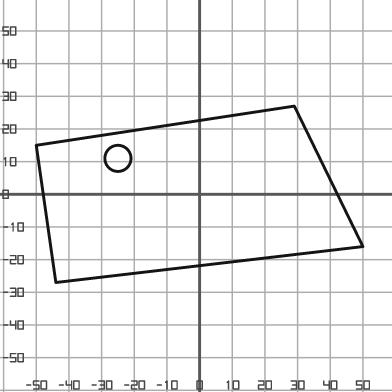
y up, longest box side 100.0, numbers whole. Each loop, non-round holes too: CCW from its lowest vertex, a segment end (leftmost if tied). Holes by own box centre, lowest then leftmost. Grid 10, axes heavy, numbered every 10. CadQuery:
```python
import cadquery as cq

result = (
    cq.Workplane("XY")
    .moveTo(-44.0, -27.0)
    .lineTo(50.0, -16.0)
    .lineTo(29.0, 27.0)
    .lineTo(-50.0, 15.0)
    .close()
    .moveTo(-25.0, 11.0)
    .circle(4.0)
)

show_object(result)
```